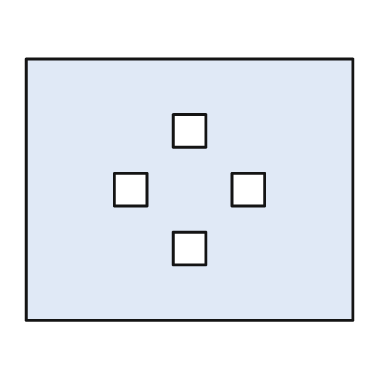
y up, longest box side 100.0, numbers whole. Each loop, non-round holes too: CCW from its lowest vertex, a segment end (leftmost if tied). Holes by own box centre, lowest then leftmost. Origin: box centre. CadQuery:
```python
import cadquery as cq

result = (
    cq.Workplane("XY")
    .moveTo(-50.0, -40.0)
    .lineTo(50.0, -40.0)
    .lineTo(50.0, 40.0)
    .lineTo(-50.0, 40.0)
    .close()
    .moveTo(-5.0, -23.0)
    .lineTo(5.0, -23.0)
    .lineTo(5.0, -13.0)
    .lineTo(-5.0, -13.0)
    .close()
    .moveTo(-23.0, -5.0)
    .lineTo(-13.0, -5.0)
    .lineTo(-13.0, 5.0)
    .lineTo(-23.0, 5.0)
    .close()
    .moveTo(13.0, -5.0)
    .lineTo(23.0, -5.0)
    .lineTo(23.0, 5.0)
    .lineTo(13.0, 5.0)
    .close()
    .moveTo(-5.0, 13.0)
    .lineTo(5.0, 13.0)
    .lineTo(5.0, 23.0)
    .lineTo(-5.0, 23.0)
    .close()
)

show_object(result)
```